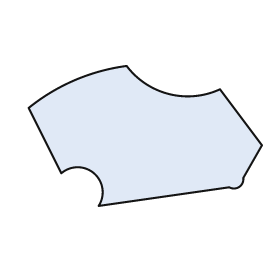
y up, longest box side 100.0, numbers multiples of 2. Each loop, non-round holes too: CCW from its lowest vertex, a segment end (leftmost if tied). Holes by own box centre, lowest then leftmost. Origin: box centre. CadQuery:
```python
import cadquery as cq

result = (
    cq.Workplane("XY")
    .moveTo(-20.0, -30.0)
    .lineTo(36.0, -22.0)
    .threePointArc((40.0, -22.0), (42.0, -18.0))
    .lineTo(50.0, -4.0)
    .lineTo(32.0, 20.0)
    .threePointArc((10.0, 18.0), (-8.0, 30.0))
    .threePointArc((-30.0, 24.0), (-50.0, 12.0))
    .lineTo(-36.0, -16.0)
    .threePointArc((-22.0, -16.0), (-20.0, -30.0))
    .close()
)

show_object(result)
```